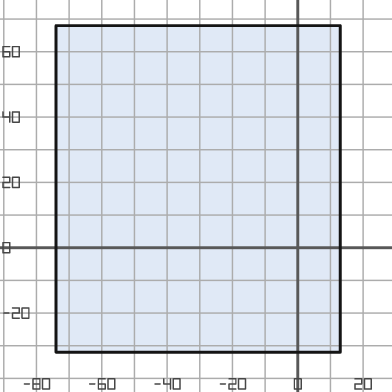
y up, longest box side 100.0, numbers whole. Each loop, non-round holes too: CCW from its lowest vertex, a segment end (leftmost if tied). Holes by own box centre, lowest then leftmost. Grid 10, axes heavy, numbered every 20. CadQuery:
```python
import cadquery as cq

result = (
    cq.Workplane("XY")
    .moveTo(-74.0, -32.0)
    .lineTo(13.0, -32.0)
    .lineTo(13.0, 68.0)
    .lineTo(-74.0, 68.0)
    .close()
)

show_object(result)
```